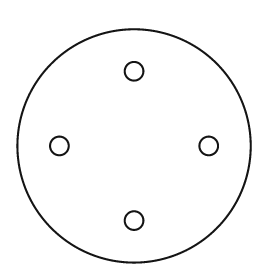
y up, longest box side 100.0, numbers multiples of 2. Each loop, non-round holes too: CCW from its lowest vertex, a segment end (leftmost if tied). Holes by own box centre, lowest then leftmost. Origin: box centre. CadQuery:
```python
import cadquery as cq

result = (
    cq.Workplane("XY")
    .moveTo(0.0, 0.0)
    .circle(50.0)
    .moveTo(0.0, -32.0)
    .circle(4.0)
    .moveTo(-32.0, 0.0)
    .circle(4.0)
    .moveTo(32.0, 0.0)
    .circle(4.0)
    .moveTo(0.0, 32.0)
    .circle(4.0)
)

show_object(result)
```